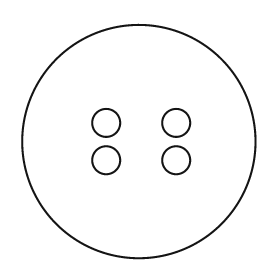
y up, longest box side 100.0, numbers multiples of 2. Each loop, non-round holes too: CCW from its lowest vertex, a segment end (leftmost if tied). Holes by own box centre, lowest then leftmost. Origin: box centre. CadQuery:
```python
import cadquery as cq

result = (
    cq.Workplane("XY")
    .moveTo(0.0, 0.0)
    .circle(50.0)
    .moveTo(-14.0, -8.0)
    .circle(6.0)
    .moveTo(16.0, -8.0)
    .circle(6.0)
    .moveTo(-14.0, 8.0)
    .circle(6.0)
    .moveTo(16.0, 8.0)
    .circle(6.0)
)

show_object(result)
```